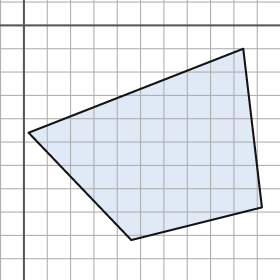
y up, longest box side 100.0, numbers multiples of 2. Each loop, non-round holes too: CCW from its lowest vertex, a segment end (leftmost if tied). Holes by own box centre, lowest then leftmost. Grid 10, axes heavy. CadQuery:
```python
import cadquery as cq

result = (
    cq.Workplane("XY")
    .moveTo(46.0, -92.0)
    .lineTo(102.0, -78.0)
    .lineTo(94.0, -10.0)
    .lineTo(2.0, -46.0)
    .close()
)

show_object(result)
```